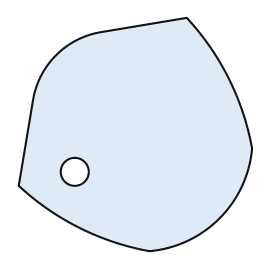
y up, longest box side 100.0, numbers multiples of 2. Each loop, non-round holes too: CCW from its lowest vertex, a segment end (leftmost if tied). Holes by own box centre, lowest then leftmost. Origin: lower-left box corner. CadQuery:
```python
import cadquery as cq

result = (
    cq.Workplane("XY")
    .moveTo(56.0, 0.0)
    .threePointArc((86.0, 14.0), (100.0, 44.0))
    .threePointArc((90.0, 74.0), (72.0, 100.0))
    .lineTo(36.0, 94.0)
    .threePointArc((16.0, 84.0), (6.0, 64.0))
    .lineTo(0.0, 28.0)
    .threePointArc((26.0, 10.0), (56.0, 0.0))
    .close()
    .moveTo(24.0, 34.0)
    .circle(6.0)
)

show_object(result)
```